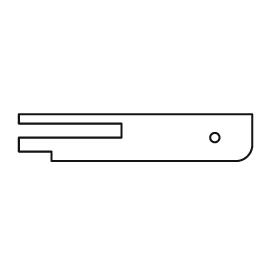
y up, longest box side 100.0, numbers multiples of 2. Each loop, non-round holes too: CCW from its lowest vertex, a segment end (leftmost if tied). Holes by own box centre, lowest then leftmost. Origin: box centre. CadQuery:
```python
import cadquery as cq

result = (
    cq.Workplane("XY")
    .moveTo(-36.0, -10.0)
    .lineTo(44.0, -10.0)
    .threePointArc((48.0, -8.0), (50.0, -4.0))
    .lineTo(50.0, 10.0)
    .lineTo(-50.0, 10.0)
    .lineTo(-50.0, 6.0)
    .lineTo(-6.0, 6.0)
    .lineTo(-6.0, 0.0)
    .lineTo(-50.0, 0.0)
    .lineTo(-50.0, -6.0)
    .lineTo(-36.0, -6.0)
    .close()
    .moveTo(34.0, 0.0)
    .circle(2.0)
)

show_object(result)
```